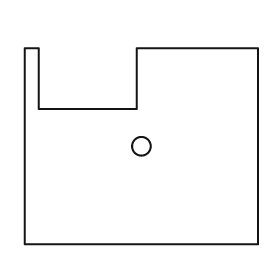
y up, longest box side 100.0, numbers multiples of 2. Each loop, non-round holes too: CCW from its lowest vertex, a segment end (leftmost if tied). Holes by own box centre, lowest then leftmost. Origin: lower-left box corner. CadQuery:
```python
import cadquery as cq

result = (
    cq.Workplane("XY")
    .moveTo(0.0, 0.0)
    .lineTo(100.0, 0.0)
    .lineTo(100.0, 84.0)
    .lineTo(48.0, 84.0)
    .lineTo(48.0, 58.0)
    .lineTo(6.0, 58.0)
    .lineTo(6.0, 84.0)
    .lineTo(0.0, 84.0)
    .close()
    .moveTo(50.0, 42.0)
    .circle(4.0)
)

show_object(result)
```